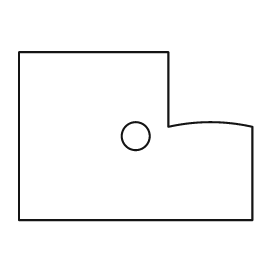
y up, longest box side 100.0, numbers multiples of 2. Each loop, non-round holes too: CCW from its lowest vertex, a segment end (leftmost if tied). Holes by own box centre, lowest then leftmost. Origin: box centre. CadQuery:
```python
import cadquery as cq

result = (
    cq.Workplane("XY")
    .moveTo(-50.0, -36.0)
    .lineTo(50.0, -36.0)
    .lineTo(50.0, 4.0)
    .threePointArc((32.0, 6.0), (14.0, 4.0))
    .lineTo(14.0, 36.0)
    .lineTo(-50.0, 36.0)
    .close()
    .moveTo(0.0, 0.0)
    .circle(6.0)
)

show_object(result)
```